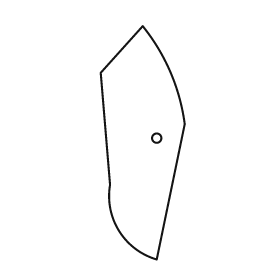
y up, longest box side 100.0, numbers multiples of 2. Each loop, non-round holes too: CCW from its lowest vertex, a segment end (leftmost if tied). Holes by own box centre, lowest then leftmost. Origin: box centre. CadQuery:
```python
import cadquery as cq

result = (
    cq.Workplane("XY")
    .moveTo(6.0, -50.0)
    .lineTo(18.0, 8.0)
    .threePointArc((12.0, 30.0), (0.0, 50.0))
    .lineTo(-18.0, 30.0)
    .lineTo(-14.0, -18.0)
    .threePointArc((-10.0, -38.0), (6.0, -50.0))
    .close()
    .moveTo(6.0, 2.0)
    .circle(2.0)
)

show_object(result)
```